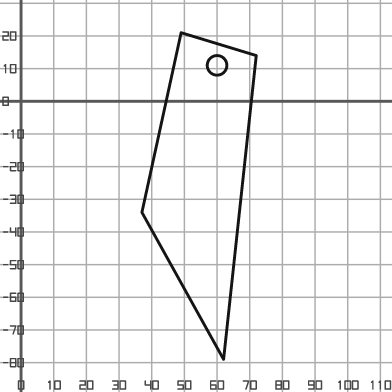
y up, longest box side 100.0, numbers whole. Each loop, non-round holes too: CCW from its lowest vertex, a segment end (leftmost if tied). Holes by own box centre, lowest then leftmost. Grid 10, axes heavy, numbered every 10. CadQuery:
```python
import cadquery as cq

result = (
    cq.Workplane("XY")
    .moveTo(62.0, -79.0)
    .lineTo(72.0, 14.0)
    .lineTo(49.0, 21.0)
    .lineTo(37.0, -34.0)
    .close()
    .moveTo(60.0, 11.0)
    .circle(3.0)
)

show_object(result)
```